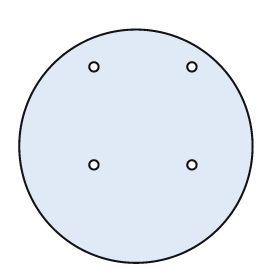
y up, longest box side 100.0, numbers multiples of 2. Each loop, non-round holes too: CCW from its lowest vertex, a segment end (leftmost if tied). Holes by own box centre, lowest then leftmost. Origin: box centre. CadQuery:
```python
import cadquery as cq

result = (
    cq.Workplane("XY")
    .moveTo(0.0, 0.0)
    .circle(50.0)
    .moveTo(-18.0, -8.0)
    .circle(2.0)
    .moveTo(24.0, -8.0)
    .circle(2.0)
    .moveTo(-18.0, 34.0)
    .circle(2.0)
    .moveTo(24.0, 34.0)
    .circle(2.0)
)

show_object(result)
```